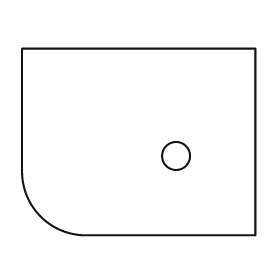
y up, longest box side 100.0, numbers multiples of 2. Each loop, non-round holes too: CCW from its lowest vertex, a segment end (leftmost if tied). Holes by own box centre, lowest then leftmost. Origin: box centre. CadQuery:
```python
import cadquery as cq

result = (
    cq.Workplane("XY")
    .moveTo(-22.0, -40.0)
    .lineTo(50.0, -40.0)
    .lineTo(50.0, 40.0)
    .lineTo(-50.0, 40.0)
    .lineTo(-50.0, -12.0)
    .threePointArc((-42.0, -32.0), (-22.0, -40.0))
    .close()
    .moveTo(16.0, -6.0)
    .circle(6.0)
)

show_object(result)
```